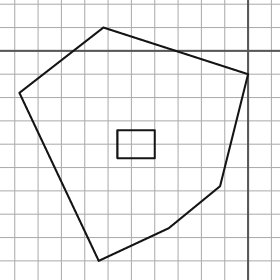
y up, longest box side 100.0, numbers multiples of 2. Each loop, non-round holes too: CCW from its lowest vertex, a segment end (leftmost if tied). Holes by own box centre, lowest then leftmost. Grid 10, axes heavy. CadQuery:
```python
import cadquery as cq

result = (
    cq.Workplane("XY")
    .moveTo(-64.0, -90.0)
    .lineTo(-34.0, -76.0)
    .lineTo(-12.0, -58.0)
    .lineTo(0.0, -10.0)
    .lineTo(-62.0, 10.0)
    .lineTo(-98.0, -18.0)
    .close()
    .moveTo(-56.0, -46.0)
    .lineTo(-40.0, -46.0)
    .lineTo(-40.0, -34.0)
    .lineTo(-56.0, -34.0)
    .close()
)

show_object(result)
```